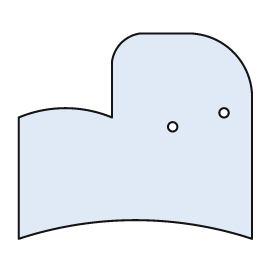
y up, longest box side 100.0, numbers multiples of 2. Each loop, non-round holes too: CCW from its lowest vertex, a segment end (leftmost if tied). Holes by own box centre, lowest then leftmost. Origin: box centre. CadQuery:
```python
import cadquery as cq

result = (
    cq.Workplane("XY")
    .moveTo(-50.0, -44.0)
    .threePointArc((0.0, -36.0), (50.0, -44.0))
    .lineTo(50.0, 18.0)
    .threePointArc((42.0, 36.0), (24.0, 44.0))
    .lineTo(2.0, 44.0)
    .threePointArc((-6.0, 40.0), (-10.0, 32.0))
    .lineTo(-10.0, 8.0)
    .threePointArc((-30.0, 12.0), (-50.0, 8.0))
    .close()
    .moveTo(16.0, 4.0)
    .circle(2.0)
    .moveTo(38.0, 10.0)
    .circle(2.0)
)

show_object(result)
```